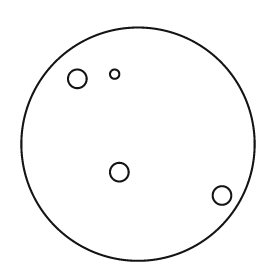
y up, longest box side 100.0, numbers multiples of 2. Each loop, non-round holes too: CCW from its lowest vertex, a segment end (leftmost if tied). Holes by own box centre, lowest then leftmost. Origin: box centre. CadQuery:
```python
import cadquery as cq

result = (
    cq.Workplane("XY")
    .moveTo(0.0, 0.0)
    .circle(50.0)
    .moveTo(36.0, -22.0)
    .circle(4.0)
    .moveTo(-8.0, -12.0)
    .circle(4.0)
    .moveTo(-26.0, 28.0)
    .circle(4.0)
    .moveTo(-10.0, 30.0)
    .circle(2.0)
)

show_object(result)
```